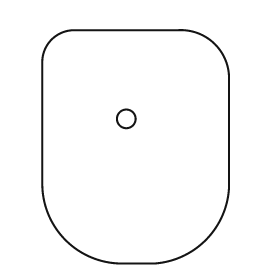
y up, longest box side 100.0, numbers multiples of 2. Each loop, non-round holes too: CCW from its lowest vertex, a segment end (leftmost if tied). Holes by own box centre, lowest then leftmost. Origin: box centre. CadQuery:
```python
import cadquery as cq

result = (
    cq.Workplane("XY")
    .moveTo(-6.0, -50.0)
    .lineTo(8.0, -50.0)
    .threePointArc((30.0, -40.0), (40.0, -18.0))
    .lineTo(40.0, 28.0)
    .threePointArc((34.0, 44.0), (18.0, 50.0))
    .lineTo(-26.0, 50.0)
    .threePointArc((-36.0, 46.0), (-40.0, 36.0))
    .lineTo(-40.0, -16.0)
    .threePointArc((-30.0, -40.0), (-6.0, -50.0))
    .close()
    .moveTo(-4.0, 12.0)
    .circle(4.0)
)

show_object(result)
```